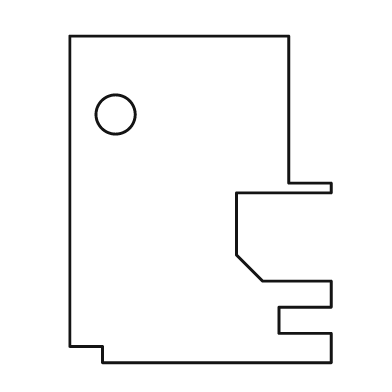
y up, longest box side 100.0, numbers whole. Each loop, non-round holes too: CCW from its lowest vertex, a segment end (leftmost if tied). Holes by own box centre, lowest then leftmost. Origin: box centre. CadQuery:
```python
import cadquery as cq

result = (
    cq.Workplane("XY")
    .moveTo(-30.0, -50.0)
    .lineTo(40.0, -50.0)
    .lineTo(40.0, -41.0)
    .lineTo(24.0, -41.0)
    .lineTo(24.0, -33.0)
    .lineTo(40.0, -33.0)
    .lineTo(40.0, -25.0)
    .lineTo(19.0, -25.0)
    .lineTo(11.0, -17.0)
    .lineTo(11.0, 2.0)
    .lineTo(40.0, 2.0)
    .lineTo(40.0, 5.0)
    .lineTo(27.0, 5.0)
    .lineTo(27.0, 50.0)
    .lineTo(-40.0, 50.0)
    .lineTo(-40.0, -45.0)
    .lineTo(-30.0, -45.0)
    .close()
    .moveTo(-26.0, 26.0)
    .circle(6.0)
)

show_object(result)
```